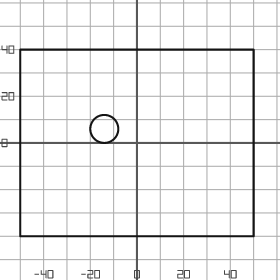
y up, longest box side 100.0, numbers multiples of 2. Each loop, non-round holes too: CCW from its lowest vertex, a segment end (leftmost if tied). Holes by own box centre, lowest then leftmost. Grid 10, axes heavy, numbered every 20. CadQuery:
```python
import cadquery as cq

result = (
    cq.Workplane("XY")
    .moveTo(-50.0, -40.0)
    .lineTo(50.0, -40.0)
    .lineTo(50.0, 40.0)
    .lineTo(-50.0, 40.0)
    .close()
    .moveTo(-14.0, 6.0)
    .circle(6.0)
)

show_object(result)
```